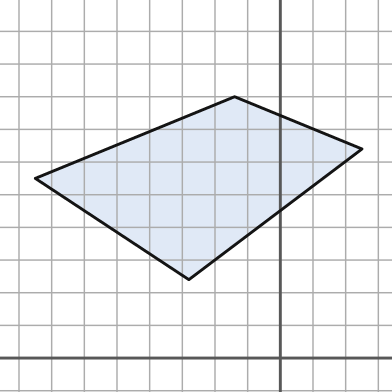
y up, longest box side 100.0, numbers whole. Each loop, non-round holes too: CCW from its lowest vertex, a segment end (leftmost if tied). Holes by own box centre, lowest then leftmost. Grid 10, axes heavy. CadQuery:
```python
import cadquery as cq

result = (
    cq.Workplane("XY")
    .moveTo(-28.0, 24.0)
    .lineTo(25.0, 64.0)
    .lineTo(-14.0, 80.0)
    .lineTo(-75.0, 55.0)
    .close()
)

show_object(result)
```